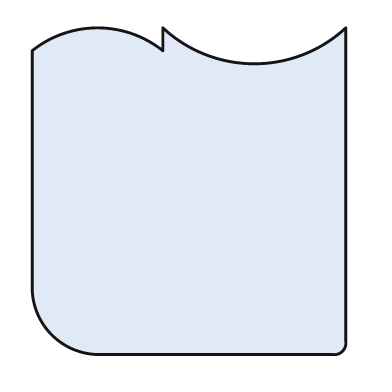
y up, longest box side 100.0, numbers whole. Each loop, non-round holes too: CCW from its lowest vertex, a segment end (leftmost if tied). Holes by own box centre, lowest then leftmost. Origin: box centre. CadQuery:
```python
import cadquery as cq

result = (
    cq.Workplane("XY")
    .moveTo(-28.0, -50.0)
    .lineTo(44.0, -50.0)
    .threePointArc((47.0, -49.0), (48.0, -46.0))
    .lineTo(48.0, 50.0)
    .threePointArc((20.0, 39.0), (-8.0, 50.0))
    .lineTo(-8.0, 43.0)
    .threePointArc((-28.0, 50.0), (-48.0, 43.0))
    .lineTo(-48.0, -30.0)
    .threePointArc((-42.0, -44.0), (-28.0, -50.0))
    .close()
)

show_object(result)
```